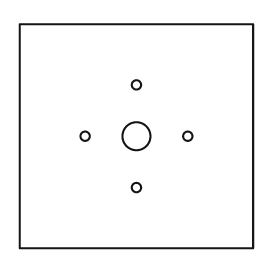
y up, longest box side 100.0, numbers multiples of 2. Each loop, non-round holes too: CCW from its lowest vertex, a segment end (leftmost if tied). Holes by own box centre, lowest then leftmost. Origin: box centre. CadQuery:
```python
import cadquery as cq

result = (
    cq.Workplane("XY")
    .moveTo(-50.0, -48.0)
    .lineTo(50.0, -48.0)
    .lineTo(50.0, 48.0)
    .lineTo(-50.0, 48.0)
    .close()
    .moveTo(0.0, -22.0)
    .circle(2.0)
    .moveTo(-22.0, 0.0)
    .circle(2.0)
    .moveTo(0.0, 0.0)
    .circle(6.0)
    .moveTo(22.0, 0.0)
    .circle(2.0)
    .moveTo(0.0, 22.0)
    .circle(2.0)
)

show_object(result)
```